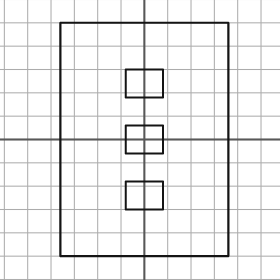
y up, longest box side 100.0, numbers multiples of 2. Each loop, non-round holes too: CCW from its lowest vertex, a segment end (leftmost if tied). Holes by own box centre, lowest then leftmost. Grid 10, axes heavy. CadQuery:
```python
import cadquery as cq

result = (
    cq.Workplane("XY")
    .moveTo(-36.0, -50.0)
    .lineTo(36.0, -50.0)
    .lineTo(36.0, 50.0)
    .lineTo(-36.0, 50.0)
    .close()
    .moveTo(-8.0, -30.0)
    .lineTo(8.0, -30.0)
    .lineTo(8.0, -18.0)
    .lineTo(-8.0, -18.0)
    .close()
    .moveTo(-8.0, -6.0)
    .lineTo(8.0, -6.0)
    .lineTo(8.0, 6.0)
    .lineTo(-8.0, 6.0)
    .close()
    .moveTo(-8.0, 18.0)
    .lineTo(8.0, 18.0)
    .lineTo(8.0, 30.0)
    .lineTo(-8.0, 30.0)
    .close()
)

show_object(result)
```